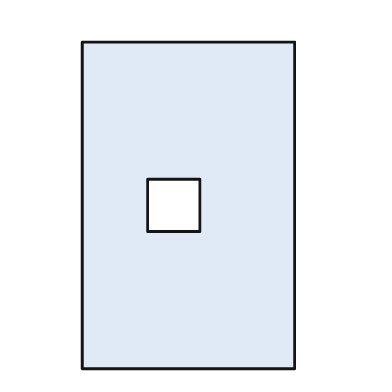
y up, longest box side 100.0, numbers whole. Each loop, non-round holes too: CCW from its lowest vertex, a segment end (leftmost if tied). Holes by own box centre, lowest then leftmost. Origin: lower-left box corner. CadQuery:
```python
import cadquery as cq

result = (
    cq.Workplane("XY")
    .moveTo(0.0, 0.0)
    .lineTo(65.0, 0.0)
    .lineTo(65.0, 100.0)
    .lineTo(0.0, 100.0)
    .close()
    .moveTo(20.0, 42.0)
    .lineTo(36.0, 42.0)
    .lineTo(36.0, 58.0)
    .lineTo(20.0, 58.0)
    .close()
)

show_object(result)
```